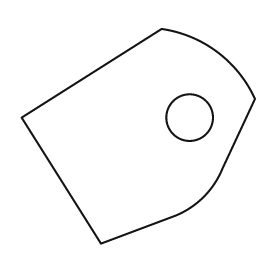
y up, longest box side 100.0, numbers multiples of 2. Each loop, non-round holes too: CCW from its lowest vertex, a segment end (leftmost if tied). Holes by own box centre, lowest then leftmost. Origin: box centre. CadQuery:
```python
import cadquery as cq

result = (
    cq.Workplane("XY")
    .moveTo(-16.0, -46.0)
    .lineTo(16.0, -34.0)
    .threePointArc((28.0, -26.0), (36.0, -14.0))
    .lineTo(50.0, 16.0)
    .threePointArc((34.0, 36.0), (10.0, 46.0))
    .lineTo(-50.0, 8.0)
    .close()
    .moveTo(22.0, 8.0)
    .circle(10.0)
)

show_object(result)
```